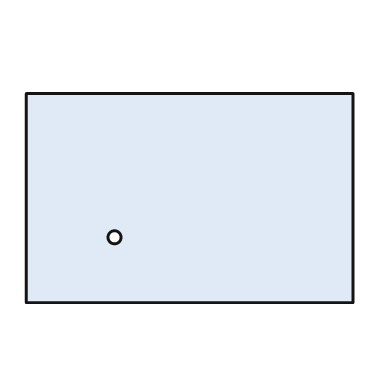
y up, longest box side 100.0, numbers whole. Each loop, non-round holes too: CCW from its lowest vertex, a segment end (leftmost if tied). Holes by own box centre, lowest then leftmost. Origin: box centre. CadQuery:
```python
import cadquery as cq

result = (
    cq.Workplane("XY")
    .moveTo(-50.0, -32.0)
    .lineTo(50.0, -32.0)
    .lineTo(50.0, 32.0)
    .lineTo(-50.0, 32.0)
    .close()
    .moveTo(-23.0, -12.0)
    .circle(2.0)
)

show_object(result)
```